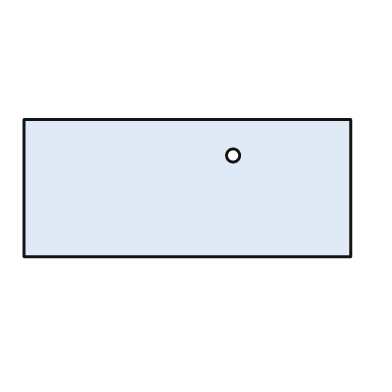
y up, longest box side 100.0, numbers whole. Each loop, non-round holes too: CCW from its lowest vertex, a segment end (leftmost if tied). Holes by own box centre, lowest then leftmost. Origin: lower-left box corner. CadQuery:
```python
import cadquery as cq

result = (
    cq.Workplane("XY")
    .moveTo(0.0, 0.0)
    .lineTo(100.0, 0.0)
    .lineTo(100.0, 42.0)
    .lineTo(0.0, 42.0)
    .close()
    .moveTo(64.0, 31.0)
    .circle(2.0)
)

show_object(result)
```